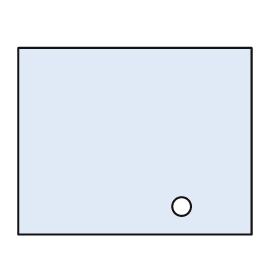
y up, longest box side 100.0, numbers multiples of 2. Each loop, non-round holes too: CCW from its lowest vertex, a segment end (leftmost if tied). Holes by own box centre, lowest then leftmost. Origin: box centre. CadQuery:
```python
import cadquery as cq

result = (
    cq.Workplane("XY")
    .moveTo(-50.0, -40.0)
    .lineTo(50.0, -40.0)
    .lineTo(50.0, 40.0)
    .lineTo(-50.0, 40.0)
    .close()
    .moveTo(20.0, -28.0)
    .circle(4.0)
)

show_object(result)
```